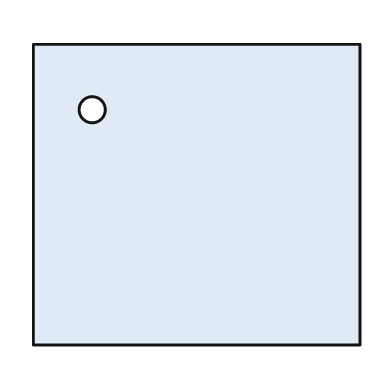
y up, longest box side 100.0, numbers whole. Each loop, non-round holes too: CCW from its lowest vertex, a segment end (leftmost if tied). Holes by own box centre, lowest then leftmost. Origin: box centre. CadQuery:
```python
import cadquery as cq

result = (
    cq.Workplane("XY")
    .moveTo(-50.0, -46.0)
    .lineTo(50.0, -46.0)
    .lineTo(50.0, 46.0)
    .lineTo(-50.0, 46.0)
    .close()
    .moveTo(-32.0, 26.0)
    .circle(4.0)
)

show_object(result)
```